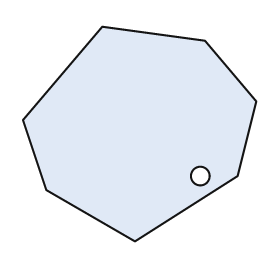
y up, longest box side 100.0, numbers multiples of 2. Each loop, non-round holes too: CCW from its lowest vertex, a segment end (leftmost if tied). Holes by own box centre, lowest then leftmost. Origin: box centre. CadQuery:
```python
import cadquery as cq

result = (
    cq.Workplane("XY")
    .moveTo(-2.0, -46.0)
    .lineTo(42.0, -18.0)
    .lineTo(50.0, 14.0)
    .lineTo(28.0, 40.0)
    .lineTo(-16.0, 46.0)
    .lineTo(-50.0, 6.0)
    .lineTo(-40.0, -24.0)
    .close()
    .moveTo(26.0, -18.0)
    .circle(4.0)
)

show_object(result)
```